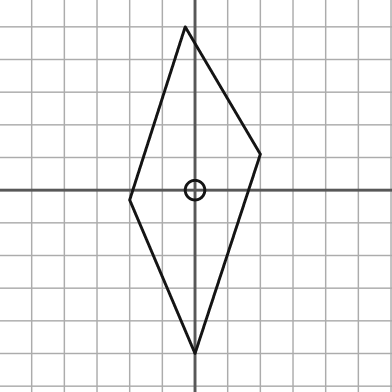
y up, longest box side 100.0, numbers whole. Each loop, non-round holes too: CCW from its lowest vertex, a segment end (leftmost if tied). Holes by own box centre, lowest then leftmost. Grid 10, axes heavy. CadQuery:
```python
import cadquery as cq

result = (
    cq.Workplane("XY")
    .moveTo(0.0, -50.0)
    .lineTo(20.0, 11.0)
    .lineTo(-3.0, 50.0)
    .lineTo(-20.0, -3.0)
    .close()
    .moveTo(0.0, 0.0)
    .circle(3.0)
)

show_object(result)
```